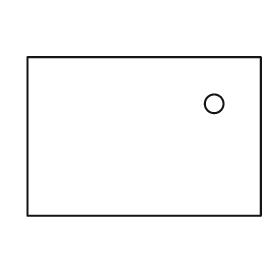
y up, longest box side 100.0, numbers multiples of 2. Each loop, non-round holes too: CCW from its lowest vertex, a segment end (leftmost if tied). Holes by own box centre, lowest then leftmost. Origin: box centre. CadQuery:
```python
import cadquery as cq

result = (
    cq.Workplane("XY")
    .moveTo(-50.0, -34.0)
    .lineTo(50.0, -34.0)
    .lineTo(50.0, 34.0)
    .lineTo(-50.0, 34.0)
    .close()
    .moveTo(30.0, 14.0)
    .circle(4.0)
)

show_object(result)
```